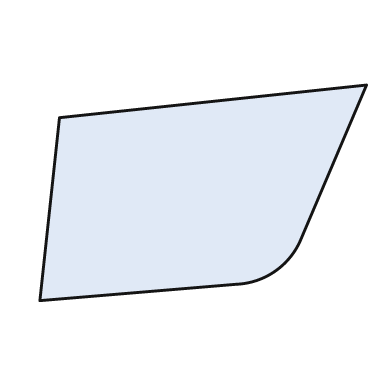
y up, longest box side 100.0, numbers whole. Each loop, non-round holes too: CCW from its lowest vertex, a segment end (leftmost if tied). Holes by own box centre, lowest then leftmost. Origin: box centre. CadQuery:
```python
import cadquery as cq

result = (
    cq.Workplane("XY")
    .moveTo(-50.0, -33.0)
    .lineTo(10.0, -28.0)
    .threePointArc((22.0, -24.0), (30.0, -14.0))
    .lineTo(50.0, 33.0)
    .lineTo(-44.0, 23.0)
    .close()
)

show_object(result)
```